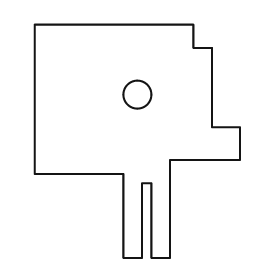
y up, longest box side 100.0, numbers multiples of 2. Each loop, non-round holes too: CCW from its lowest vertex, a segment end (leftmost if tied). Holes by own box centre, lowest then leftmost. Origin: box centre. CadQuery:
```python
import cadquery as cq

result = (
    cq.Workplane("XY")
    .moveTo(-6.0, -50.0)
    .lineTo(2.0, -50.0)
    .lineTo(2.0, -18.0)
    .lineTo(6.0, -18.0)
    .lineTo(6.0, -50.0)
    .lineTo(14.0, -50.0)
    .lineTo(14.0, -8.0)
    .lineTo(44.0, -8.0)
    .lineTo(44.0, 6.0)
    .lineTo(32.0, 6.0)
    .lineTo(32.0, 40.0)
    .lineTo(24.0, 40.0)
    .lineTo(24.0, 50.0)
    .lineTo(-44.0, 50.0)
    .lineTo(-44.0, -14.0)
    .lineTo(-6.0, -14.0)
    .close()
    .moveTo(0.0, 20.0)
    .circle(6.0)
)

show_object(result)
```